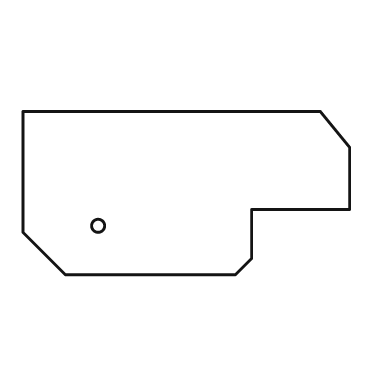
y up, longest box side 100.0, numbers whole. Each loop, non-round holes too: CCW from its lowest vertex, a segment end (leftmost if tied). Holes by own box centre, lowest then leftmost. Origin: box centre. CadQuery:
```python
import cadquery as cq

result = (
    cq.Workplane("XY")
    .moveTo(-37.0, -25.0)
    .lineTo(15.0, -25.0)
    .lineTo(20.0, -20.0)
    .lineTo(20.0, -5.0)
    .lineTo(50.0, -5.0)
    .lineTo(50.0, 14.0)
    .lineTo(41.0, 25.0)
    .lineTo(-50.0, 25.0)
    .lineTo(-50.0, -12.0)
    .close()
    .moveTo(-27.0, -10.0)
    .circle(2.0)
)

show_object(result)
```